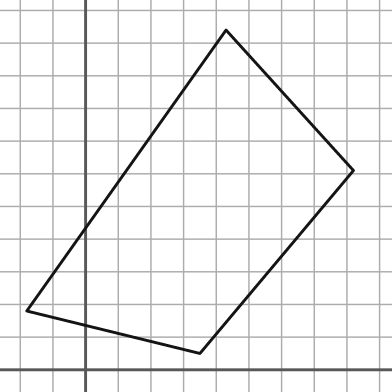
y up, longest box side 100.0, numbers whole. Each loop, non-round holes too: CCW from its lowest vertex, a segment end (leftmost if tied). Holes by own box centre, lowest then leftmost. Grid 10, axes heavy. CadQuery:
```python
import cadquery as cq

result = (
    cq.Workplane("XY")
    .moveTo(35.0, 5.0)
    .lineTo(82.0, 61.0)
    .lineTo(43.0, 104.0)
    .lineTo(-18.0, 18.0)
    .close()
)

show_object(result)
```